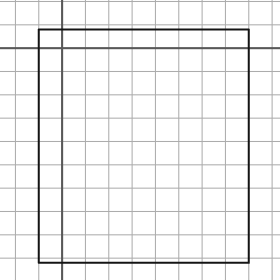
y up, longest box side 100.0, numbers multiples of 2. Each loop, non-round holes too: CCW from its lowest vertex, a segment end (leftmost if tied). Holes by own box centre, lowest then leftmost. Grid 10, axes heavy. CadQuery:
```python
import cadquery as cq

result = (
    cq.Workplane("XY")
    .moveTo(-10.0, -92.0)
    .lineTo(80.0, -92.0)
    .lineTo(80.0, 8.0)
    .lineTo(-10.0, 8.0)
    .close()
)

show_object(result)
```